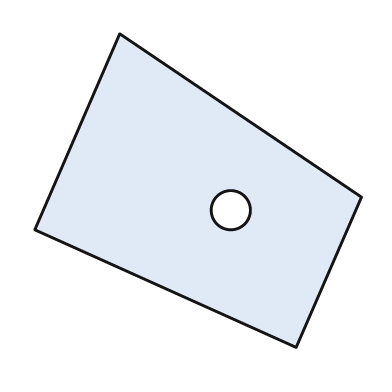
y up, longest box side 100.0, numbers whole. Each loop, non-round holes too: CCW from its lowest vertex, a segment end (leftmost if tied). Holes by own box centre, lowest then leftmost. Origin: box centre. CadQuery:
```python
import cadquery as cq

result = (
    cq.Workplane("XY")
    .moveTo(30.0, -48.0)
    .lineTo(50.0, -2.0)
    .lineTo(-24.0, 48.0)
    .lineTo(-50.0, -12.0)
    .close()
    .moveTo(10.0, -6.0)
    .circle(6.0)
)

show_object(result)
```